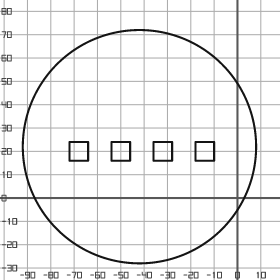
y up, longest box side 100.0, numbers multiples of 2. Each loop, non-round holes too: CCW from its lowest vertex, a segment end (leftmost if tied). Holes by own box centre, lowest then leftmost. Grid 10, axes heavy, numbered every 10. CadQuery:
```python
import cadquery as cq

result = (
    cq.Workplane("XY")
    .moveTo(-42.0, 22.0)
    .circle(50.0)
    .moveTo(-72.0, 16.0)
    .lineTo(-64.0, 16.0)
    .lineTo(-64.0, 24.0)
    .lineTo(-72.0, 24.0)
    .close()
    .moveTo(-54.0, 16.0)
    .lineTo(-46.0, 16.0)
    .lineTo(-46.0, 24.0)
    .lineTo(-54.0, 24.0)
    .close()
    .moveTo(-36.0, 16.0)
    .lineTo(-28.0, 16.0)
    .lineTo(-28.0, 24.0)
    .lineTo(-36.0, 24.0)
    .close()
    .moveTo(-18.0, 16.0)
    .lineTo(-10.0, 16.0)
    .lineTo(-10.0, 24.0)
    .lineTo(-18.0, 24.0)
    .close()
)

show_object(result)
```